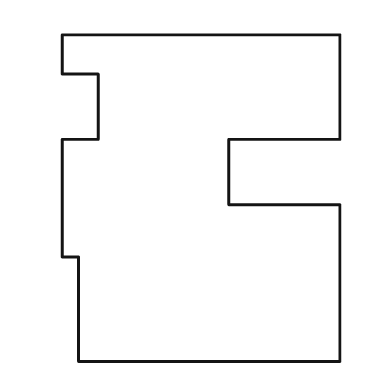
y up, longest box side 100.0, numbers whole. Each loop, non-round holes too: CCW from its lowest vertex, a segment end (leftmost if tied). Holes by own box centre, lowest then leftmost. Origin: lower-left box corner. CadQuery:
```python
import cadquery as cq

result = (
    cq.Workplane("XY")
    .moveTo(5.0, 0.0)
    .lineTo(85.0, 0.0)
    .lineTo(85.0, 48.0)
    .lineTo(51.0, 48.0)
    .lineTo(51.0, 68.0)
    .lineTo(85.0, 68.0)
    .lineTo(85.0, 100.0)
    .lineTo(0.0, 100.0)
    .lineTo(0.0, 88.0)
    .lineTo(11.0, 88.0)
    .lineTo(11.0, 68.0)
    .lineTo(0.0, 68.0)
    .lineTo(0.0, 32.0)
    .lineTo(5.0, 32.0)
    .close()
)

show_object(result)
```